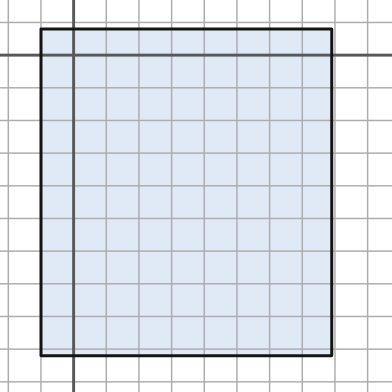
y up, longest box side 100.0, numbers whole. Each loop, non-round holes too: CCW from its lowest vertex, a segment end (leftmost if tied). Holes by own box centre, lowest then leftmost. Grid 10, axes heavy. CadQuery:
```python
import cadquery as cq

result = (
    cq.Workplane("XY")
    .moveTo(-10.0, -92.0)
    .lineTo(79.0, -92.0)
    .lineTo(79.0, 8.0)
    .lineTo(-10.0, 8.0)
    .close()
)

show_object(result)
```